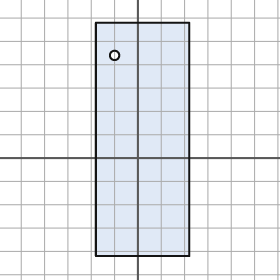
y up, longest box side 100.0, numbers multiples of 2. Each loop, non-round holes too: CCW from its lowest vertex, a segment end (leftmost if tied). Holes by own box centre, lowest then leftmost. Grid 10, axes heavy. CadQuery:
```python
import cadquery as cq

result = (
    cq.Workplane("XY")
    .moveTo(-18.0, -42.0)
    .lineTo(22.0, -42.0)
    .lineTo(22.0, 58.0)
    .lineTo(-18.0, 58.0)
    .close()
    .moveTo(-10.0, 44.0)
    .circle(2.0)
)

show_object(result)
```